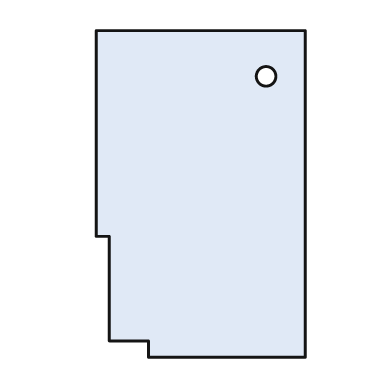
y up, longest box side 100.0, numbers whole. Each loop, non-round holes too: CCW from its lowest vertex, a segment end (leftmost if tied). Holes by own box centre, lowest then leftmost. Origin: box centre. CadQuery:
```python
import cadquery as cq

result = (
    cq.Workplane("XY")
    .moveTo(-16.0, -50.0)
    .lineTo(32.0, -50.0)
    .lineTo(32.0, 50.0)
    .lineTo(-32.0, 50.0)
    .lineTo(-32.0, -13.0)
    .lineTo(-28.0, -13.0)
    .lineTo(-28.0, -45.0)
    .lineTo(-16.0, -45.0)
    .close()
    .moveTo(20.0, 36.0)
    .circle(3.0)
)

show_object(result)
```